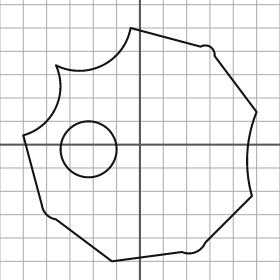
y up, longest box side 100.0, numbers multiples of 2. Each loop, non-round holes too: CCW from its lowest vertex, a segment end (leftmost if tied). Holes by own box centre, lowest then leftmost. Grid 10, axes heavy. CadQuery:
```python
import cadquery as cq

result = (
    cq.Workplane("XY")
    .moveTo(-12.0, -50.0)
    .lineTo(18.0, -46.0)
    .threePointArc((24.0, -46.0), (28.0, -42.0))
    .lineTo(48.0, -22.0)
    .threePointArc((46.0, -4.0), (50.0, 14.0))
    .lineTo(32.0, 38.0)
    .threePointArc((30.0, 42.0), (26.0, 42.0))
    .lineTo(-4.0, 50.0)
    .threePointArc((-16.0, 34.0), (-36.0, 34.0))
    .threePointArc((-36.0, 16.0), (-50.0, 4.0))
    .lineTo(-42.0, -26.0)
    .threePointArc((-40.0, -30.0), (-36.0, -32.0))
    .close()
    .moveTo(-22.0, -2.0)
    .circle(12.0)
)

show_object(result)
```